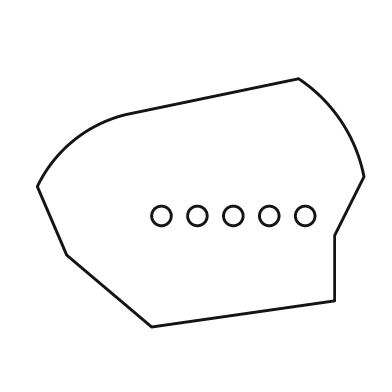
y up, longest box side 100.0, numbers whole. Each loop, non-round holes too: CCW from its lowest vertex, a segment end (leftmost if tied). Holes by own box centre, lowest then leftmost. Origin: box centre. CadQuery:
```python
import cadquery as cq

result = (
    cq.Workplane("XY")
    .moveTo(-15.0, -38.0)
    .lineTo(41.0, -30.0)
    .lineTo(41.0, -10.0)
    .lineTo(50.0, 8.0)
    .threePointArc((43.0, 25.0), (30.0, 38.0))
    .lineTo(-23.0, 27.0)
    .threePointArc((-39.0, 19.0), (-50.0, 5.0))
    .lineTo(-41.0, -16.0)
    .close()
    .moveTo(-12.0, -4.0)
    .circle(3.0)
    .moveTo(-1.0, -4.0)
    .circle(3.0)
    .moveTo(10.0, -4.0)
    .circle(3.0)
    .moveTo(21.0, -4.0)
    .circle(3.0)
    .moveTo(32.0, -4.0)
    .circle(3.0)
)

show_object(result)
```